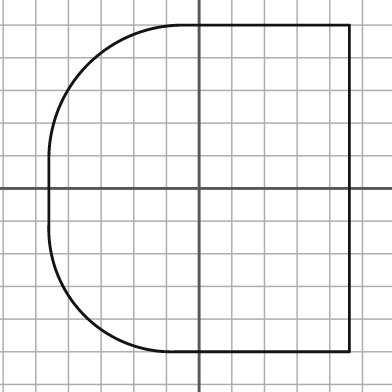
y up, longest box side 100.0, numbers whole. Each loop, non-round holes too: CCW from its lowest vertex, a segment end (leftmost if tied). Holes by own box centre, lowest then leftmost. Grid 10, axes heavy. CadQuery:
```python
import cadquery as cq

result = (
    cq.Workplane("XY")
    .moveTo(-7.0, -50.0)
    .lineTo(46.0, -50.0)
    .lineTo(46.0, 50.0)
    .lineTo(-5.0, 50.0)
    .threePointArc((-34.0, 38.0), (-46.0, 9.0))
    .lineTo(-46.0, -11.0)
    .threePointArc((-35.0, -39.0), (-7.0, -50.0))
    .close()
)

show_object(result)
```